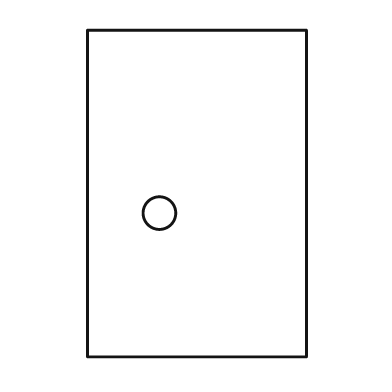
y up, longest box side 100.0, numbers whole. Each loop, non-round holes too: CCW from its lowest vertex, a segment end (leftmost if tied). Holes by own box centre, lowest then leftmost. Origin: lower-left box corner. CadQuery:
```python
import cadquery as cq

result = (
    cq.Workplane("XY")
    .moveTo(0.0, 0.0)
    .lineTo(67.0, 0.0)
    .lineTo(67.0, 100.0)
    .lineTo(0.0, 100.0)
    .close()
    .moveTo(22.0, 44.0)
    .circle(5.0)
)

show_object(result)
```